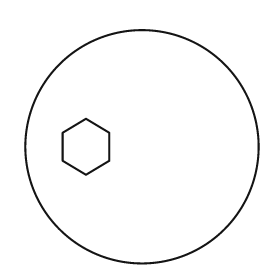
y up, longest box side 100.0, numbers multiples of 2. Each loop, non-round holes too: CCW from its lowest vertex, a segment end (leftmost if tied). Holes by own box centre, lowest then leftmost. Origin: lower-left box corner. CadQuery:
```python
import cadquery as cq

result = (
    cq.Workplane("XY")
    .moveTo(50.0, 50.0)
    .circle(50.0)
    .moveTo(26.0, 38.0)
    .lineTo(36.0, 44.0)
    .lineTo(36.0, 56.0)
    .lineTo(26.0, 62.0)
    .lineTo(16.0, 56.0)
    .lineTo(16.0, 44.0)
    .close()
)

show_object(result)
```